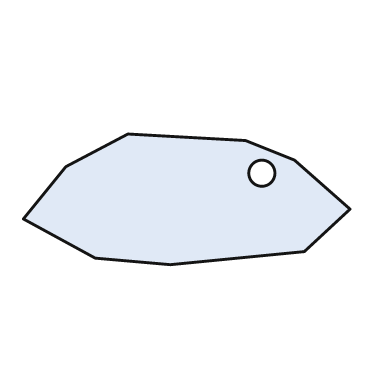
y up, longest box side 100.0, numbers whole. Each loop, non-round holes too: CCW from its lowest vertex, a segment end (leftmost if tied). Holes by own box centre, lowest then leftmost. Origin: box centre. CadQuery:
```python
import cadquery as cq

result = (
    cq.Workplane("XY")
    .moveTo(-5.0, -20.0)
    .lineTo(36.0, -16.0)
    .lineTo(50.0, -3.0)
    .lineTo(33.0, 12.0)
    .lineTo(18.0, 18.0)
    .lineTo(-18.0, 20.0)
    .lineTo(-37.0, 10.0)
    .lineTo(-50.0, -6.0)
    .lineTo(-28.0, -18.0)
    .close()
    .moveTo(23.0, 8.0)
    .circle(4.0)
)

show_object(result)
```